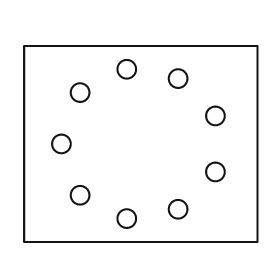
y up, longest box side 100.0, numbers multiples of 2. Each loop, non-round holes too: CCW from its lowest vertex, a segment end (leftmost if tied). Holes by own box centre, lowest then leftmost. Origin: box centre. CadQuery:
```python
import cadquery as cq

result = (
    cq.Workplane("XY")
    .moveTo(-50.0, -42.0)
    .lineTo(50.0, -42.0)
    .lineTo(50.0, 42.0)
    .lineTo(-50.0, 42.0)
    .close()
    .moveTo(-6.0, -32.0)
    .circle(4.0)
    .moveTo(16.0, -28.0)
    .circle(4.0)
    .moveTo(-26.0, -22.0)
    .circle(4.0)
    .moveTo(32.0, -12.0)
    .circle(4.0)
    .moveTo(-34.0, 0.0)
    .circle(4.0)
    .moveTo(32.0, 12.0)
    .circle(4.0)
    .moveTo(-26.0, 22.0)
    .circle(4.0)
    .moveTo(16.0, 28.0)
    .circle(4.0)
    .moveTo(-6.0, 32.0)
    .circle(4.0)
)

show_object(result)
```